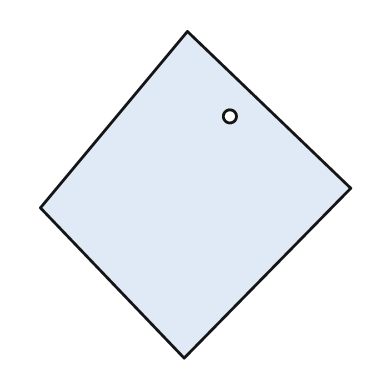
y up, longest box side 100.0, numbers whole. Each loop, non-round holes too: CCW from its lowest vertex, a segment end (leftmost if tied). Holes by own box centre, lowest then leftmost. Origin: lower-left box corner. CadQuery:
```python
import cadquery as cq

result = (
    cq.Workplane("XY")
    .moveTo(44.0, 0.0)
    .lineTo(95.0, 52.0)
    .lineTo(45.0, 100.0)
    .lineTo(0.0, 46.0)
    .close()
    .moveTo(58.0, 74.0)
    .circle(2.0)
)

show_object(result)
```